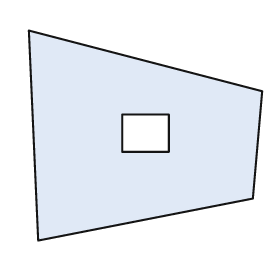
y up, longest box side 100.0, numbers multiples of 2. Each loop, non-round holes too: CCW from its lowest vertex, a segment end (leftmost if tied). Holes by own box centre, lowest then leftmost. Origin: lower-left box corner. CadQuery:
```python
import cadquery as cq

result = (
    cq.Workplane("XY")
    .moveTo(4.0, 0.0)
    .lineTo(96.0, 18.0)
    .lineTo(100.0, 64.0)
    .lineTo(0.0, 90.0)
    .close()
    .moveTo(40.0, 38.0)
    .lineTo(60.0, 38.0)
    .lineTo(60.0, 54.0)
    .lineTo(40.0, 54.0)
    .close()
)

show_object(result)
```